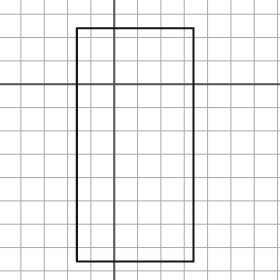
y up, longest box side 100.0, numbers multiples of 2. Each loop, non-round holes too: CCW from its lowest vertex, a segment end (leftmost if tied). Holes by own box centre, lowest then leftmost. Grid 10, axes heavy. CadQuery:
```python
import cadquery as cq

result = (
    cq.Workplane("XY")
    .moveTo(-16.0, -76.0)
    .lineTo(34.0, -76.0)
    .lineTo(34.0, 24.0)
    .lineTo(-16.0, 24.0)
    .close()
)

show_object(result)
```